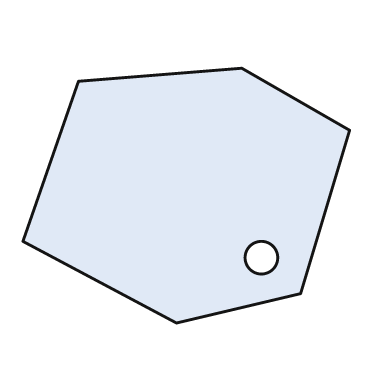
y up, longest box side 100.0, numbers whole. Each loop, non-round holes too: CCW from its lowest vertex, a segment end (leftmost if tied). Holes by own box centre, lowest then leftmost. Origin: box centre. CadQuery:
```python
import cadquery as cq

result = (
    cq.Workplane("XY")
    .moveTo(-3.0, -39.0)
    .lineTo(35.0, -30.0)
    .lineTo(50.0, 20.0)
    .lineTo(17.0, 39.0)
    .lineTo(-33.0, 35.0)
    .lineTo(-50.0, -14.0)
    .close()
    .moveTo(23.0, -19.0)
    .circle(5.0)
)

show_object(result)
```